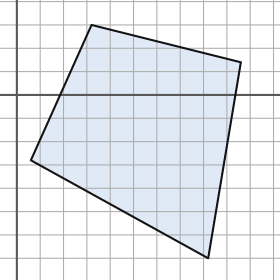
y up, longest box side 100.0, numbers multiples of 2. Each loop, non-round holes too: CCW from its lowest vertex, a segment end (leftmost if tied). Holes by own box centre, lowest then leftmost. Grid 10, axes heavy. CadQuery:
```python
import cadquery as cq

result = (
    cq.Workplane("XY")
    .moveTo(82.0, -70.0)
    .lineTo(96.0, 14.0)
    .lineTo(32.0, 30.0)
    .lineTo(6.0, -28.0)
    .close()
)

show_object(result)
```